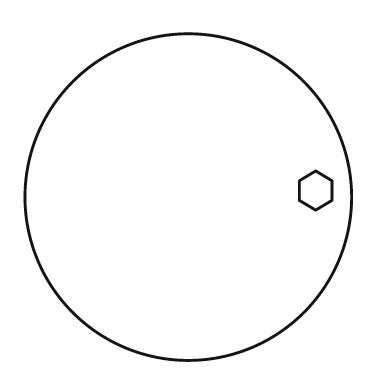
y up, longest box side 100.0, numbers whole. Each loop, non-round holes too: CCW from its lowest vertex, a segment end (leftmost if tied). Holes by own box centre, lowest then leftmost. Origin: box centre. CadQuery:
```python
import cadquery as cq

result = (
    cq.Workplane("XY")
    .moveTo(0.0, 0.0)
    .circle(50.0)
    .moveTo(39.0, -4.0)
    .lineTo(44.0, -1.0)
    .lineTo(44.0, 5.0)
    .lineTo(39.0, 8.0)
    .lineTo(34.0, 5.0)
    .lineTo(34.0, -1.0)
    .close()
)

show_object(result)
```